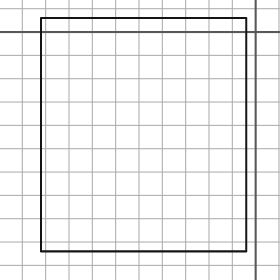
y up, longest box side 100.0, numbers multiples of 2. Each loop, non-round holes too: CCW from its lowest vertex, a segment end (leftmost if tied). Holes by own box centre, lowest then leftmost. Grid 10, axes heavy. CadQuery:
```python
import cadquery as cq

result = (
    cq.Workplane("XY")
    .moveTo(-92.0, -94.0)
    .lineTo(-4.0, -94.0)
    .lineTo(-4.0, 6.0)
    .lineTo(-92.0, 6.0)
    .close()
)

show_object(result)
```